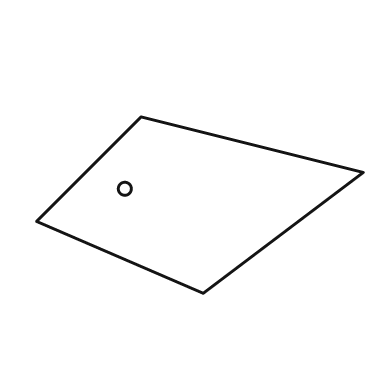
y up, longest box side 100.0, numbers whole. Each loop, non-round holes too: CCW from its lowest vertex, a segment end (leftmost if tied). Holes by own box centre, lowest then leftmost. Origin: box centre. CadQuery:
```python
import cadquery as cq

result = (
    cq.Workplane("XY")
    .moveTo(1.0, -27.0)
    .lineTo(50.0, 10.0)
    .lineTo(-18.0, 27.0)
    .lineTo(-50.0, -5.0)
    .close()
    .moveTo(-23.0, 5.0)
    .circle(2.0)
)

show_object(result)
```